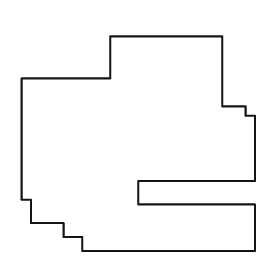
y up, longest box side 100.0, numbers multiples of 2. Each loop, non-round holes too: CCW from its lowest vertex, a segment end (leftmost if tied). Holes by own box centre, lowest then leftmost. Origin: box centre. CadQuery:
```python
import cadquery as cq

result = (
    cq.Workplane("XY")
    .moveTo(-24.0, -46.0)
    .lineTo(50.0, -46.0)
    .lineTo(50.0, -26.0)
    .lineTo(0.0, -26.0)
    .lineTo(0.0, -16.0)
    .lineTo(50.0, -16.0)
    .lineTo(50.0, 12.0)
    .lineTo(46.0, 12.0)
    .lineTo(46.0, 16.0)
    .lineTo(36.0, 16.0)
    .lineTo(36.0, 46.0)
    .lineTo(-12.0, 46.0)
    .lineTo(-12.0, 28.0)
    .lineTo(-50.0, 28.0)
    .lineTo(-50.0, -24.0)
    .lineTo(-46.0, -24.0)
    .lineTo(-46.0, -34.0)
    .lineTo(-32.0, -34.0)
    .lineTo(-32.0, -40.0)
    .lineTo(-24.0, -40.0)
    .close()
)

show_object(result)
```